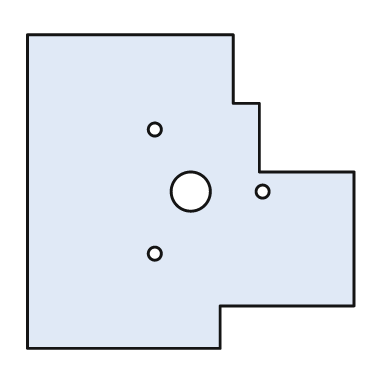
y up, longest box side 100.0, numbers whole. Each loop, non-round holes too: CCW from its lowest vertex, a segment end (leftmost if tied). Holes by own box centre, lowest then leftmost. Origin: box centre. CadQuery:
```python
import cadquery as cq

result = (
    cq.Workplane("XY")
    .moveTo(-50.0, -48.0)
    .lineTo(9.0, -48.0)
    .lineTo(9.0, -35.0)
    .lineTo(50.0, -35.0)
    .lineTo(50.0, 6.0)
    .lineTo(21.0, 6.0)
    .lineTo(21.0, 27.0)
    .lineTo(13.0, 27.0)
    .lineTo(13.0, 48.0)
    .lineTo(-50.0, 48.0)
    .close()
    .moveTo(-11.0, -19.0)
    .circle(2.0)
    .moveTo(0.0, 0.0)
    .circle(6.0)
    .moveTo(22.0, 0.0)
    .circle(2.0)
    .moveTo(-11.0, 19.0)
    .circle(2.0)
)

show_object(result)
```